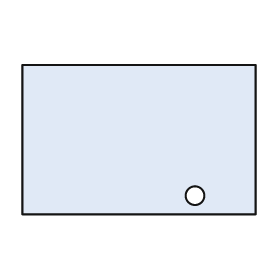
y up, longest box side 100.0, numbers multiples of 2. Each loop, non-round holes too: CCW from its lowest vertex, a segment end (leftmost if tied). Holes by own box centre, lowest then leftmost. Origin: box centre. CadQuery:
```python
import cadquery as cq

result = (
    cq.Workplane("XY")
    .moveTo(-50.0, -32.0)
    .lineTo(50.0, -32.0)
    .lineTo(50.0, 32.0)
    .lineTo(-50.0, 32.0)
    .close()
    .moveTo(24.0, -24.0)
    .circle(4.0)
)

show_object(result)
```